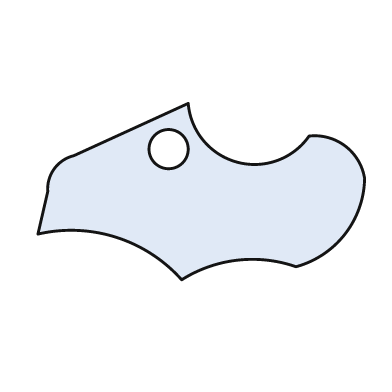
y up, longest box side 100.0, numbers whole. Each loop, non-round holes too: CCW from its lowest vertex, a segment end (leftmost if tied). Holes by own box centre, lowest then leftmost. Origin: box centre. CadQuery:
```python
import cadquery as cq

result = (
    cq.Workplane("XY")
    .moveTo(-6.0, -27.0)
    .threePointArc((11.0, -21.0), (29.0, -23.0))
    .threePointArc((44.0, -13.0), (50.0, 4.0))
    .threePointArc((44.0, 14.0), (33.0, 17.0))
    .threePointArc((11.0, 9.0), (-4.0, 27.0))
    .lineTo(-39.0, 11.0)
    .threePointArc((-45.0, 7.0), (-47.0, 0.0))
    .lineTo(-50.0, -13.0)
    .threePointArc((-26.0, -14.0), (-6.0, -27.0))
    .close()
    .moveTo(-10.0, 13.0)
    .circle(6.0)
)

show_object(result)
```